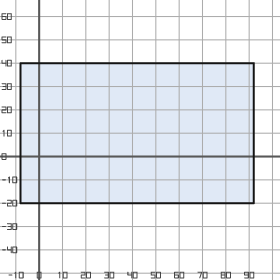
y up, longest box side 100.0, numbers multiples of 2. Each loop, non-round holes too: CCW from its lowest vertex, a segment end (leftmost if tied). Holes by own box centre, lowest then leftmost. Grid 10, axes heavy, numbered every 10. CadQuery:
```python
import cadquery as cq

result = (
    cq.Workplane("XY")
    .moveTo(-8.0, -20.0)
    .lineTo(92.0, -20.0)
    .lineTo(92.0, 40.0)
    .lineTo(-8.0, 40.0)
    .close()
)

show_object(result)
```